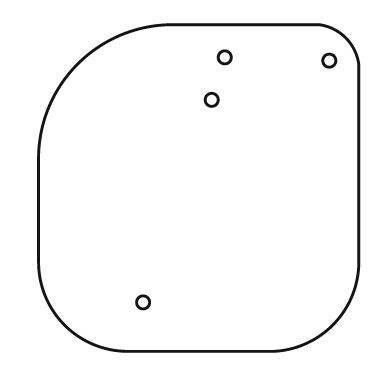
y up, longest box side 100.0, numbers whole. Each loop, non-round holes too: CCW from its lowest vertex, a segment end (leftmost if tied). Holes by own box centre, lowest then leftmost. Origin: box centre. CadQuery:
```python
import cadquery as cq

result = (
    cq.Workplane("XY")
    .moveTo(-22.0, -50.0)
    .lineTo(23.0, -50.0)
    .threePointArc((41.0, -42.0), (49.0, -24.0))
    .lineTo(49.0, 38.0)
    .threePointArc((45.0, 46.0), (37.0, 50.0))
    .lineTo(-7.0, 50.0)
    .threePointArc((-37.0, 38.0), (-49.0, 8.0))
    .lineTo(-49.0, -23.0)
    .threePointArc((-41.0, -42.0), (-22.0, -50.0))
    .close()
    .moveTo(-17.0, -35.0)
    .circle(2.0)
    .moveTo(4.0, 27.0)
    .circle(2.0)
    .moveTo(40.0, 39.0)
    .circle(2.0)
    .moveTo(8.0, 40.0)
    .circle(2.0)
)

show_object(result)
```